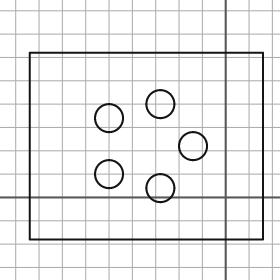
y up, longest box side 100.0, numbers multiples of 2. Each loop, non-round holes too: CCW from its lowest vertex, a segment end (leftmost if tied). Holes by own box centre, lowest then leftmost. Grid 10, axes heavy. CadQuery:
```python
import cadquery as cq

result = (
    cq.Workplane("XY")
    .moveTo(-84.0, -18.0)
    .lineTo(16.0, -18.0)
    .lineTo(16.0, 62.0)
    .lineTo(-84.0, 62.0)
    .close()
    .moveTo(-28.0, 4.0)
    .circle(6.0)
    .moveTo(-50.0, 10.0)
    .circle(6.0)
    .moveTo(-14.0, 22.0)
    .circle(6.0)
    .moveTo(-50.0, 34.0)
    .circle(6.0)
    .moveTo(-28.0, 40.0)
    .circle(6.0)
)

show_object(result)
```